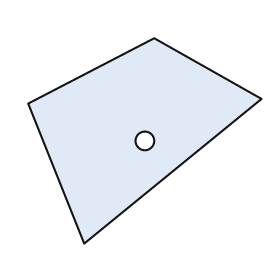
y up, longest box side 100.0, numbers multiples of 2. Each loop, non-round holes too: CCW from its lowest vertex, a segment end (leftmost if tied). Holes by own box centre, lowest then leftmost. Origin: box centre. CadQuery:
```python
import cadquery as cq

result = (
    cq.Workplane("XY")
    .moveTo(-26.0, -44.0)
    .lineTo(50.0, 18.0)
    .lineTo(4.0, 44.0)
    .lineTo(-50.0, 16.0)
    .close()
    .moveTo(0.0, 0.0)
    .circle(4.0)
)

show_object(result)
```